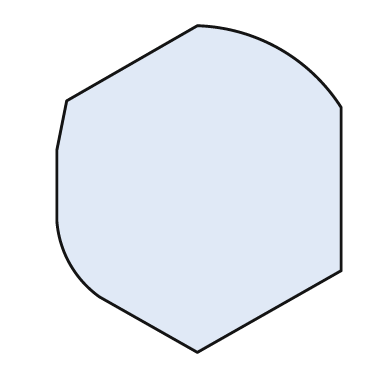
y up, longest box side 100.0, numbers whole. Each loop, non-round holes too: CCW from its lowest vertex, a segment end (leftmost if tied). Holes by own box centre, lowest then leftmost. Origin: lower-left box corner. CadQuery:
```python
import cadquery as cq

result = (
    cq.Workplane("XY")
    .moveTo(43.0, 0.0)
    .lineTo(87.0, 25.0)
    .lineTo(87.0, 75.0)
    .threePointArc((68.0, 93.0), (43.0, 100.0))
    .lineTo(3.0, 77.0)
    .lineTo(0.0, 62.0)
    .lineTo(0.0, 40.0)
    .threePointArc((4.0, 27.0), (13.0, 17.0))
    .close()
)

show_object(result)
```